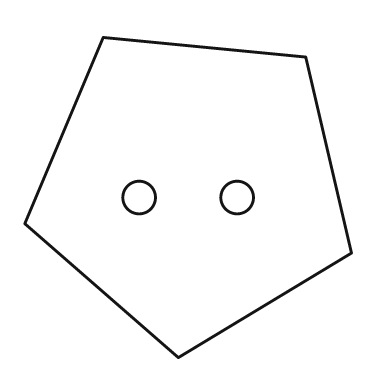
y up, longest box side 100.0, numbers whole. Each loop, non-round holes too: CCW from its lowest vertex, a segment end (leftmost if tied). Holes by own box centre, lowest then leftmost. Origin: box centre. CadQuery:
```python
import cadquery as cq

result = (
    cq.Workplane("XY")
    .moveTo(-3.0, -49.0)
    .lineTo(50.0, -17.0)
    .lineTo(36.0, 43.0)
    .lineTo(-26.0, 49.0)
    .lineTo(-50.0, -8.0)
    .close()
    .moveTo(-15.0, 0.0)
    .circle(5.0)
    .moveTo(15.0, 0.0)
    .circle(5.0)
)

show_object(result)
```